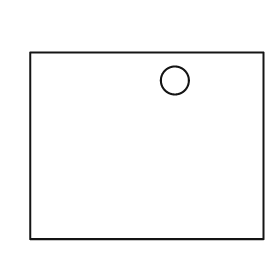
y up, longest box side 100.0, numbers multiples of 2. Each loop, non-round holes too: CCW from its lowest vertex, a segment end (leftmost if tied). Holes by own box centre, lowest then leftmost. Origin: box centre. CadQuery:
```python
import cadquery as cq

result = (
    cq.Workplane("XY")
    .moveTo(-50.0, -40.0)
    .lineTo(50.0, -40.0)
    .lineTo(50.0, 40.0)
    .lineTo(-50.0, 40.0)
    .close()
    .moveTo(12.0, 28.0)
    .circle(6.0)
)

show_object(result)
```